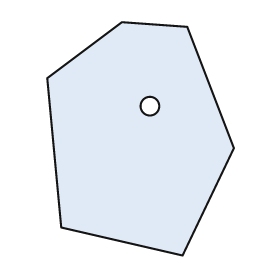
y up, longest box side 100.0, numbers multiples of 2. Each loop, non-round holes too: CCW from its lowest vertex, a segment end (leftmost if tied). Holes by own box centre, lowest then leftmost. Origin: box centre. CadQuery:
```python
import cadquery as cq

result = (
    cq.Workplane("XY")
    .moveTo(18.0, -50.0)
    .lineTo(40.0, -4.0)
    .lineTo(20.0, 48.0)
    .lineTo(-8.0, 50.0)
    .lineTo(-40.0, 26.0)
    .lineTo(-34.0, -38.0)
    .close()
    .moveTo(4.0, 14.0)
    .circle(4.0)
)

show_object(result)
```